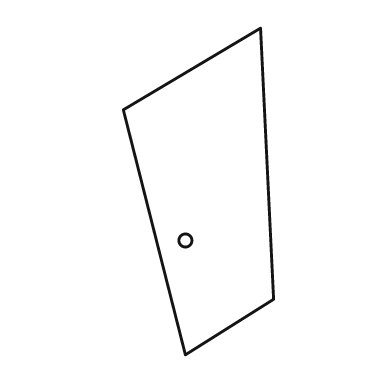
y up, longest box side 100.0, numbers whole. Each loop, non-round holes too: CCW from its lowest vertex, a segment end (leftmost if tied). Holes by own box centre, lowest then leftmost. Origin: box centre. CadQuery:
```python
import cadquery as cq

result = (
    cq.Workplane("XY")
    .moveTo(-4.0, -50.0)
    .lineTo(23.0, -33.0)
    .lineTo(19.0, 50.0)
    .lineTo(-23.0, 25.0)
    .close()
    .moveTo(-4.0, -15.0)
    .circle(2.0)
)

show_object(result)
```